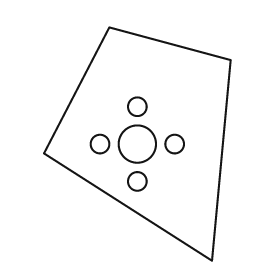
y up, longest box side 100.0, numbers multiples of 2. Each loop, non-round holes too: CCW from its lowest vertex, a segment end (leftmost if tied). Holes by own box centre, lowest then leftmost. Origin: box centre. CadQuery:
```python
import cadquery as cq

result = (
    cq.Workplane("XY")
    .moveTo(32.0, -50.0)
    .lineTo(40.0, 36.0)
    .lineTo(-12.0, 50.0)
    .lineTo(-40.0, -4.0)
    .close()
    .moveTo(0.0, -16.0)
    .circle(4.0)
    .moveTo(-16.0, 0.0)
    .circle(4.0)
    .moveTo(0.0, 0.0)
    .circle(8.0)
    .moveTo(16.0, 0.0)
    .circle(4.0)
    .moveTo(0.0, 16.0)
    .circle(4.0)
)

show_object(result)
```